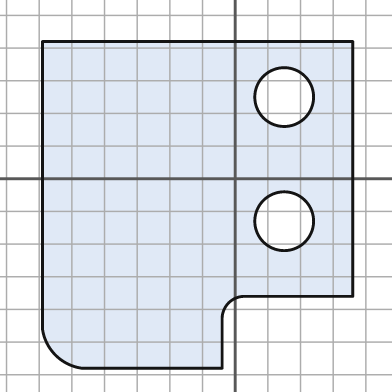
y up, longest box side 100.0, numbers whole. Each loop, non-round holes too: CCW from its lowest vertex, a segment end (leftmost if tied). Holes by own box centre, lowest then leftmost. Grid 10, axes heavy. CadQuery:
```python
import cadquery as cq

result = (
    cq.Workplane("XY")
    .moveTo(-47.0, -58.0)
    .lineTo(-4.0, -58.0)
    .lineTo(-4.0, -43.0)
    .threePointArc((-2.0, -38.0), (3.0, -36.0))
    .lineTo(36.0, -36.0)
    .lineTo(36.0, 42.0)
    .lineTo(-59.0, 42.0)
    .lineTo(-59.0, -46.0)
    .threePointArc((-55.0, -54.0), (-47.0, -58.0))
    .close()
    .moveTo(15.0, -13.0)
    .circle(9.0)
    .moveTo(15.0, 25.0)
    .circle(9.0)
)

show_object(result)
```